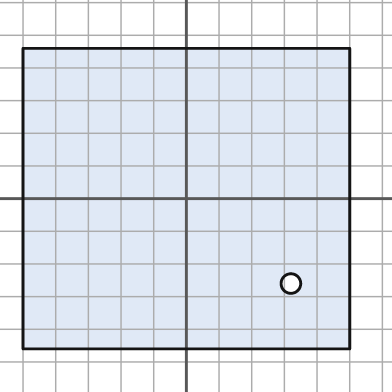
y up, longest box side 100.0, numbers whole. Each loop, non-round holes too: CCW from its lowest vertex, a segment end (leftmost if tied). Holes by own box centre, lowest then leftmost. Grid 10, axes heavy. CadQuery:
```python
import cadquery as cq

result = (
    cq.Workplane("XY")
    .moveTo(-50.0, -46.0)
    .lineTo(50.0, -46.0)
    .lineTo(50.0, 46.0)
    .lineTo(-50.0, 46.0)
    .close()
    .moveTo(32.0, -26.0)
    .circle(3.0)
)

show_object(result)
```